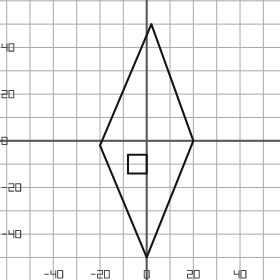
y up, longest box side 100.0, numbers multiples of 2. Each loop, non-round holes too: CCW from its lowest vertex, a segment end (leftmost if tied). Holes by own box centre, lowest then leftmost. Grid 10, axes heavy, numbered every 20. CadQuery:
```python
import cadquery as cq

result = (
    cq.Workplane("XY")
    .moveTo(0.0, -50.0)
    .lineTo(20.0, 0.0)
    .lineTo(2.0, 50.0)
    .lineTo(-20.0, -2.0)
    .close()
    .moveTo(-8.0, -14.0)
    .lineTo(0.0, -14.0)
    .lineTo(0.0, -6.0)
    .lineTo(-8.0, -6.0)
    .close()
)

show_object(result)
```